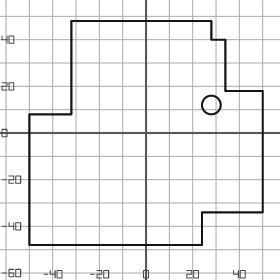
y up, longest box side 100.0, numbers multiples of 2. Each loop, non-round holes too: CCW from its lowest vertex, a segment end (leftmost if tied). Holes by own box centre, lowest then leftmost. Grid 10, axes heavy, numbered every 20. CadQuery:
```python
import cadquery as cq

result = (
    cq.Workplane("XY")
    .moveTo(-50.0, -48.0)
    .lineTo(24.0, -48.0)
    .lineTo(24.0, -34.0)
    .lineTo(50.0, -34.0)
    .lineTo(50.0, 18.0)
    .lineTo(34.0, 18.0)
    .lineTo(34.0, 40.0)
    .lineTo(28.0, 40.0)
    .lineTo(28.0, 48.0)
    .lineTo(-32.0, 48.0)
    .lineTo(-32.0, 8.0)
    .lineTo(-50.0, 8.0)
    .close()
    .moveTo(28.0, 12.0)
    .circle(4.0)
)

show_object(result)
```